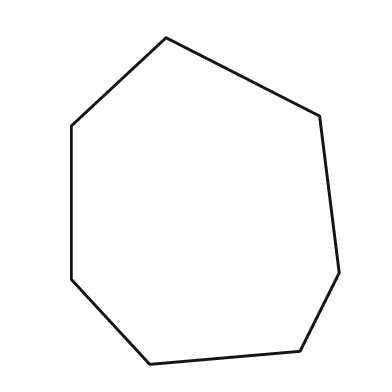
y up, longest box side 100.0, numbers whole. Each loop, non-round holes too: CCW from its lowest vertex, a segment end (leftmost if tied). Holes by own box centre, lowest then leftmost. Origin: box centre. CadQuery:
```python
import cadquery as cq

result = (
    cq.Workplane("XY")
    .moveTo(-17.0, -50.0)
    .lineTo(29.0, -46.0)
    .lineTo(41.0, -22.0)
    .lineTo(35.0, 26.0)
    .lineTo(-12.0, 50.0)
    .lineTo(-41.0, 23.0)
    .lineTo(-41.0, -24.0)
    .close()
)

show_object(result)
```